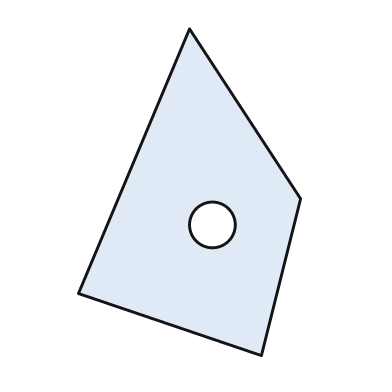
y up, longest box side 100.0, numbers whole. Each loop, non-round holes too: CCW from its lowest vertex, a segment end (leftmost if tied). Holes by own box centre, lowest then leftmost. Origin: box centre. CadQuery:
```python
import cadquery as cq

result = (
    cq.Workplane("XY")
    .moveTo(22.0, -50.0)
    .lineTo(34.0, -2.0)
    .lineTo(0.0, 50.0)
    .lineTo(-34.0, -31.0)
    .close()
    .moveTo(7.0, -10.0)
    .circle(7.0)
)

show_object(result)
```